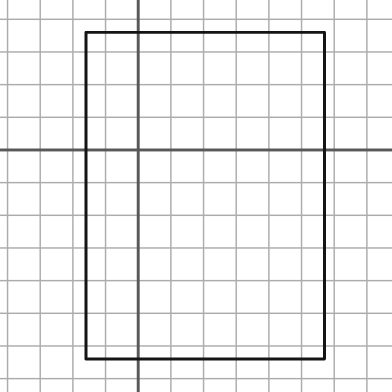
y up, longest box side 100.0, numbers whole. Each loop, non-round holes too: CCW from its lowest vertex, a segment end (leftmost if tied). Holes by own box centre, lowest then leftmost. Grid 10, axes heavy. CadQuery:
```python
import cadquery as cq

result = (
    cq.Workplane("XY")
    .moveTo(-16.0, -64.0)
    .lineTo(57.0, -64.0)
    .lineTo(57.0, 36.0)
    .lineTo(-16.0, 36.0)
    .close()
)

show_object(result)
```